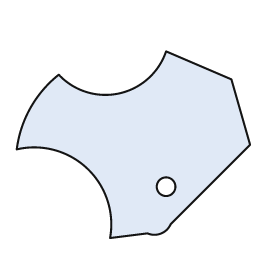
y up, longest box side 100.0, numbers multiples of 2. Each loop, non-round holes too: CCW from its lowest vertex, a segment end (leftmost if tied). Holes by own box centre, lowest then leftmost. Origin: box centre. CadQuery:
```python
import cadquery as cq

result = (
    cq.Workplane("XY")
    .moveTo(-10.0, -40.0)
    .lineTo(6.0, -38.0)
    .threePointArc((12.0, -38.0), (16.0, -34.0))
    .lineTo(50.0, 0.0)
    .lineTo(42.0, 28.0)
    .lineTo(14.0, 40.0)
    .threePointArc((-6.0, 22.0), (-32.0, 30.0))
    .threePointArc((-44.0, 16.0), (-50.0, -2.0))
    .threePointArc((-20.0, -10.0), (-10.0, -40.0))
    .close()
    .moveTo(14.0, -18.0)
    .circle(4.0)
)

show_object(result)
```